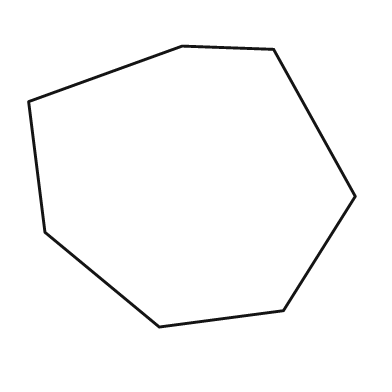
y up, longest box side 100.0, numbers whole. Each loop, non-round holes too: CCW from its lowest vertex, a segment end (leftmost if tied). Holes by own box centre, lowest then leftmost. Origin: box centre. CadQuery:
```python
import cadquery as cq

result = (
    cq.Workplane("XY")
    .moveTo(-10.0, -43.0)
    .lineTo(28.0, -38.0)
    .lineTo(50.0, -3.0)
    .lineTo(25.0, 42.0)
    .lineTo(-3.0, 43.0)
    .lineTo(-50.0, 26.0)
    .lineTo(-45.0, -14.0)
    .close()
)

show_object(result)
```